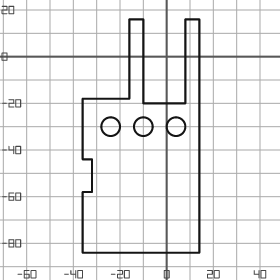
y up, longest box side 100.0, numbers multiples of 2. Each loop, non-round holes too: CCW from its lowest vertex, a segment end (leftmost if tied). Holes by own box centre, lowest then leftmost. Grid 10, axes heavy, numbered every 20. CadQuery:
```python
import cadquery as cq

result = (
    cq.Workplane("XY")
    .moveTo(-36.0, -84.0)
    .lineTo(14.0, -84.0)
    .lineTo(14.0, 16.0)
    .lineTo(8.0, 16.0)
    .lineTo(8.0, -20.0)
    .lineTo(-10.0, -20.0)
    .lineTo(-10.0, 16.0)
    .lineTo(-16.0, 16.0)
    .lineTo(-16.0, -18.0)
    .lineTo(-36.0, -18.0)
    .lineTo(-36.0, -44.0)
    .lineTo(-32.0, -44.0)
    .lineTo(-32.0, -58.0)
    .lineTo(-36.0, -58.0)
    .close()
    .moveTo(-24.0, -30.0)
    .circle(4.0)
    .moveTo(-10.0, -30.0)
    .circle(4.0)
    .moveTo(4.0, -30.0)
    .circle(4.0)
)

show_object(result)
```